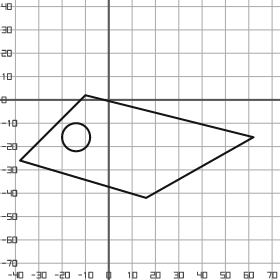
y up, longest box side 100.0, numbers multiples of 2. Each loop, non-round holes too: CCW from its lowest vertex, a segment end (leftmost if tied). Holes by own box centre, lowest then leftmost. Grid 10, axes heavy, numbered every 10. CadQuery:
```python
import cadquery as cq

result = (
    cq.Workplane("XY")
    .moveTo(16.0, -42.0)
    .lineTo(62.0, -16.0)
    .lineTo(-10.0, 2.0)
    .lineTo(-38.0, -26.0)
    .close()
    .moveTo(-14.0, -16.0)
    .circle(6.0)
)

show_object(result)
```